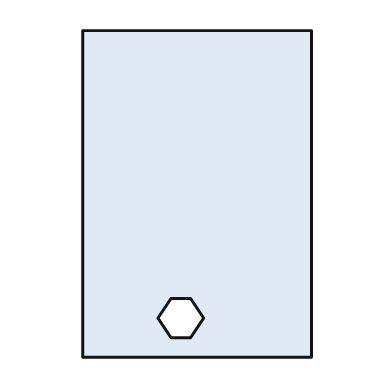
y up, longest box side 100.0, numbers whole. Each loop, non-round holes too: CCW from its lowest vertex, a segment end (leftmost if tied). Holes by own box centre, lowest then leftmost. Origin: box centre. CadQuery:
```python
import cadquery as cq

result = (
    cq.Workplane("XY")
    .moveTo(-35.0, -50.0)
    .lineTo(35.0, -50.0)
    .lineTo(35.0, 50.0)
    .lineTo(-35.0, 50.0)
    .close()
    .moveTo(-8.0, -44.0)
    .lineTo(-2.0, -44.0)
    .lineTo(2.0, -38.0)
    .lineTo(-2.0, -32.0)
    .lineTo(-8.0, -32.0)
    .lineTo(-12.0, -38.0)
    .close()
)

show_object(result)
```